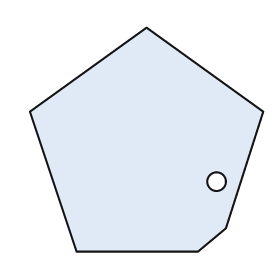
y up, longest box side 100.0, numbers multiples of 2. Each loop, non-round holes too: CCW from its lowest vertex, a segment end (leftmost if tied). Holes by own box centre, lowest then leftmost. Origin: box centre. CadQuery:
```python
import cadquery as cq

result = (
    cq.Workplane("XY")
    .moveTo(-30.0, -48.0)
    .lineTo(22.0, -48.0)
    .lineTo(34.0, -38.0)
    .lineTo(50.0, 12.0)
    .lineTo(0.0, 48.0)
    .lineTo(-50.0, 12.0)
    .close()
    .moveTo(30.0, -18.0)
    .circle(4.0)
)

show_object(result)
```